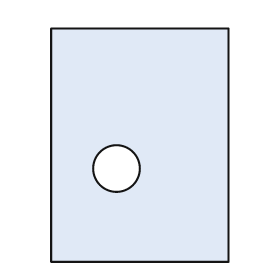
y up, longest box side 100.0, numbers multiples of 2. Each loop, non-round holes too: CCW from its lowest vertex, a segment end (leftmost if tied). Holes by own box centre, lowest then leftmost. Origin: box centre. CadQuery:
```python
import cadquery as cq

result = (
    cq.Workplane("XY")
    .moveTo(-38.0, -50.0)
    .lineTo(38.0, -50.0)
    .lineTo(38.0, 50.0)
    .lineTo(-38.0, 50.0)
    .close()
    .moveTo(-10.0, -10.0)
    .circle(10.0)
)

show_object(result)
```